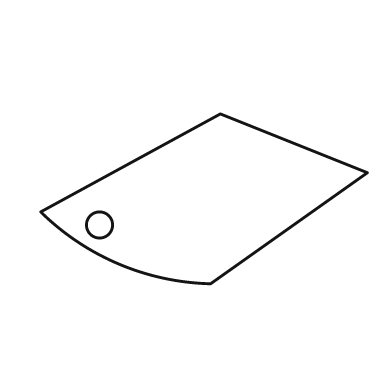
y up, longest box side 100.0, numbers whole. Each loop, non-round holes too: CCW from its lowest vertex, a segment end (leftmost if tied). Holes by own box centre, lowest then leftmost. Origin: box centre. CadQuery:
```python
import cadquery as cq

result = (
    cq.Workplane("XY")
    .moveTo(2.0, -26.0)
    .lineTo(50.0, 8.0)
    .lineTo(5.0, 26.0)
    .lineTo(-50.0, -4.0)
    .threePointArc((-26.0, -20.0), (2.0, -26.0))
    .close()
    .moveTo(-32.0, -8.0)
    .circle(4.0)
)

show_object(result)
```